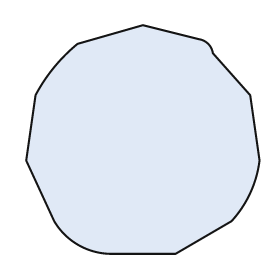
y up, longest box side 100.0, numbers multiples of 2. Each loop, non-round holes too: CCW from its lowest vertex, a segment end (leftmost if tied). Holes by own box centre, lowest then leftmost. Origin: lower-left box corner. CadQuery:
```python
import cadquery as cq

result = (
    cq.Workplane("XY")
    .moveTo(36.0, 0.0)
    .lineTo(64.0, 0.0)
    .lineTo(88.0, 14.0)
    .threePointArc((96.0, 26.0), (100.0, 40.0))
    .lineTo(96.0, 68.0)
    .lineTo(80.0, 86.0)
    .threePointArc((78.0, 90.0), (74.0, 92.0))
    .lineTo(50.0, 98.0)
    .lineTo(22.0, 90.0)
    .threePointArc((12.0, 80.0), (4.0, 68.0))
    .lineTo(0.0, 40.0)
    .lineTo(12.0, 14.0)
    .threePointArc((22.0, 4.0), (36.0, 0.0))
    .close()
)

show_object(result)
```